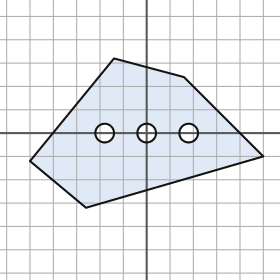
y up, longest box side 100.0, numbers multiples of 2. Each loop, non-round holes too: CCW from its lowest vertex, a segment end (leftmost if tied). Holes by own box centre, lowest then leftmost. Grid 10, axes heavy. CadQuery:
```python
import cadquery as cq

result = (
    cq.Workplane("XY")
    .moveTo(-26.0, -32.0)
    .lineTo(50.0, -10.0)
    .lineTo(16.0, 24.0)
    .lineTo(-14.0, 32.0)
    .lineTo(-50.0, -12.0)
    .close()
    .moveTo(-18.0, 0.0)
    .circle(4.0)
    .moveTo(0.0, 0.0)
    .circle(4.0)
    .moveTo(18.0, 0.0)
    .circle(4.0)
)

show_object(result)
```